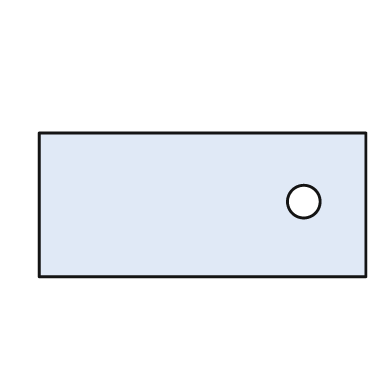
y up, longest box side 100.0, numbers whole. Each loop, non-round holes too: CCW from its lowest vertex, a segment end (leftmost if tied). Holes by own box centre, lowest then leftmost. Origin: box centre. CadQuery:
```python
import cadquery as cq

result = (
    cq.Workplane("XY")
    .moveTo(-50.0, -22.0)
    .lineTo(50.0, -22.0)
    .lineTo(50.0, 22.0)
    .lineTo(-50.0, 22.0)
    .close()
    .moveTo(31.0, 1.0)
    .circle(5.0)
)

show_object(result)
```